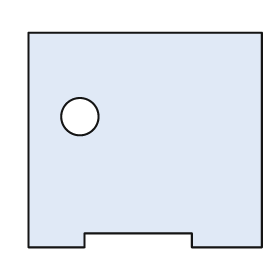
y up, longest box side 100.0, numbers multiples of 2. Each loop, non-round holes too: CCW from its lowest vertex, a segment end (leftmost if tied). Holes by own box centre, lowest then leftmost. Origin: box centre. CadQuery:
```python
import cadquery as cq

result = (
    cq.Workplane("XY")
    .moveTo(-50.0, -46.0)
    .lineTo(-26.0, -46.0)
    .lineTo(-26.0, -40.0)
    .lineTo(20.0, -40.0)
    .lineTo(20.0, -46.0)
    .lineTo(50.0, -46.0)
    .lineTo(50.0, 46.0)
    .lineTo(-50.0, 46.0)
    .close()
    .moveTo(-28.0, 10.0)
    .circle(8.0)
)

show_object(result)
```